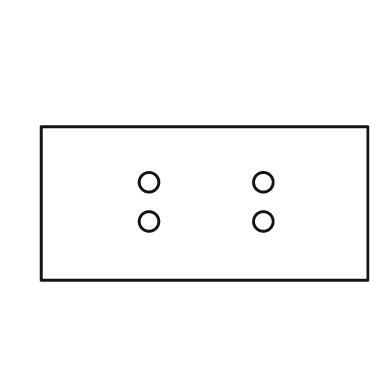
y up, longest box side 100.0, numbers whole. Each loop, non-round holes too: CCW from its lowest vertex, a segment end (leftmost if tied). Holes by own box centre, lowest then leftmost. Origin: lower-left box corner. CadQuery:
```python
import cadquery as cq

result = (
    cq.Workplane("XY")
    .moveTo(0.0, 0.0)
    .lineTo(100.0, 0.0)
    .lineTo(100.0, 47.0)
    .lineTo(0.0, 47.0)
    .close()
    .moveTo(33.0, 18.0)
    .circle(3.0)
    .moveTo(68.0, 18.0)
    .circle(3.0)
    .moveTo(33.0, 30.0)
    .circle(3.0)
    .moveTo(68.0, 30.0)
    .circle(3.0)
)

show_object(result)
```